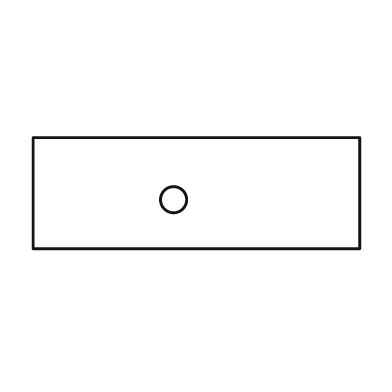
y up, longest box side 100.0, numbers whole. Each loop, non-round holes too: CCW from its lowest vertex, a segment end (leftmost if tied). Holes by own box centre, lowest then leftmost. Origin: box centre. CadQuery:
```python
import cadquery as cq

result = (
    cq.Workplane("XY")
    .moveTo(-50.0, -17.0)
    .lineTo(50.0, -17.0)
    .lineTo(50.0, 17.0)
    .lineTo(-50.0, 17.0)
    .close()
    .moveTo(-7.0, -2.0)
    .circle(4.0)
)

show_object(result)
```